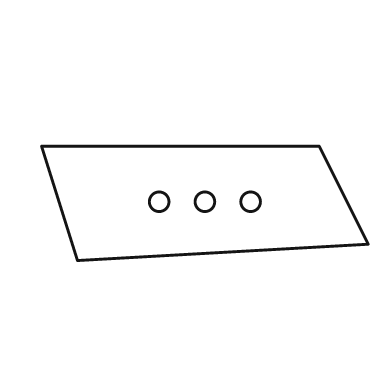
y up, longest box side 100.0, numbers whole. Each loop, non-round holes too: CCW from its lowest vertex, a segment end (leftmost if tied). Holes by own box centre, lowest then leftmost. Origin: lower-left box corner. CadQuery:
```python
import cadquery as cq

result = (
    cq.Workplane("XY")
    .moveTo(11.0, 0.0)
    .lineTo(100.0, 5.0)
    .lineTo(85.0, 35.0)
    .lineTo(0.0, 35.0)
    .close()
    .moveTo(36.0, 18.0)
    .circle(3.0)
    .moveTo(50.0, 18.0)
    .circle(3.0)
    .moveTo(64.0, 18.0)
    .circle(3.0)
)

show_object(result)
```